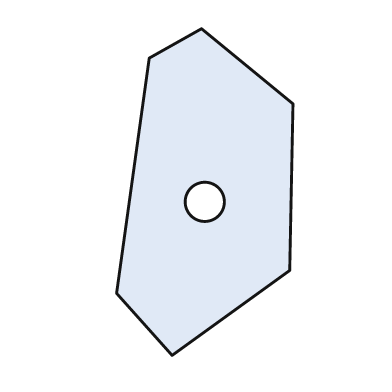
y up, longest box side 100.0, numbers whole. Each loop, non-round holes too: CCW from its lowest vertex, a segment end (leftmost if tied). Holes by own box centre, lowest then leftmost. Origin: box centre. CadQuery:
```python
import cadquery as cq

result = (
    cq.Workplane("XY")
    .moveTo(-10.0, -50.0)
    .lineTo(26.0, -24.0)
    .lineTo(27.0, 27.0)
    .lineTo(-1.0, 50.0)
    .lineTo(-17.0, 41.0)
    .lineTo(-27.0, -31.0)
    .close()
    .moveTo(0.0, -3.0)
    .circle(6.0)
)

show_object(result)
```